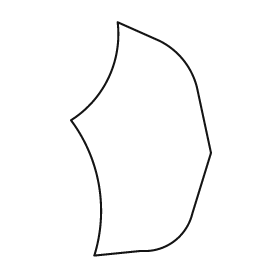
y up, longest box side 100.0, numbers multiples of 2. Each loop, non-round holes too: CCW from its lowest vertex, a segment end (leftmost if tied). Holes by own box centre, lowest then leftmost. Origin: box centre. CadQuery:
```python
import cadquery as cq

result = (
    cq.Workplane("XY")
    .moveTo(-20.0, -50.0)
    .lineTo(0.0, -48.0)
    .threePointArc((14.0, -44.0), (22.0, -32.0))
    .lineTo(30.0, -6.0)
    .lineTo(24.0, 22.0)
    .threePointArc((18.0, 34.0), (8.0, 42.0))
    .lineTo(-10.0, 50.0)
    .threePointArc((-14.0, 26.0), (-30.0, 8.0))
    .threePointArc((-18.0, -20.0), (-20.0, -50.0))
    .close()
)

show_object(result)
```